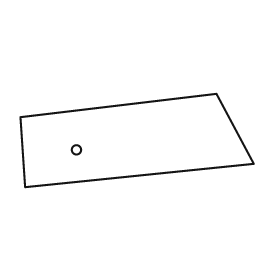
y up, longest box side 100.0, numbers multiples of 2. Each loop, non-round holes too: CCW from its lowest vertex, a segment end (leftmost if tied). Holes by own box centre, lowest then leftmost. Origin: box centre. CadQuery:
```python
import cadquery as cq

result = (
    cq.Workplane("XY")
    .moveTo(-48.0, -20.0)
    .lineTo(50.0, -10.0)
    .lineTo(34.0, 20.0)
    .lineTo(-50.0, 10.0)
    .close()
    .moveTo(-26.0, -4.0)
    .circle(2.0)
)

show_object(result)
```